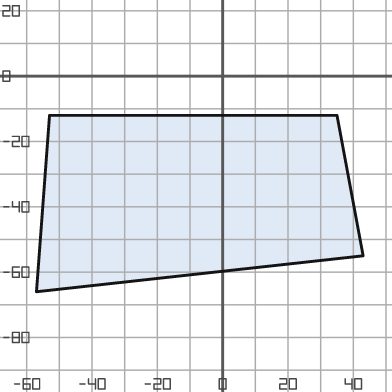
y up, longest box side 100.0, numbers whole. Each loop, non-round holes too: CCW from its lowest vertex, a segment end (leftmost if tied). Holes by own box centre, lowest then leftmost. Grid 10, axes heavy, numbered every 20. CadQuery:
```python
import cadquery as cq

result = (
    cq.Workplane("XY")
    .moveTo(-57.0, -66.0)
    .lineTo(43.0, -55.0)
    .lineTo(35.0, -12.0)
    .lineTo(-53.0, -12.0)
    .close()
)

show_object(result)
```